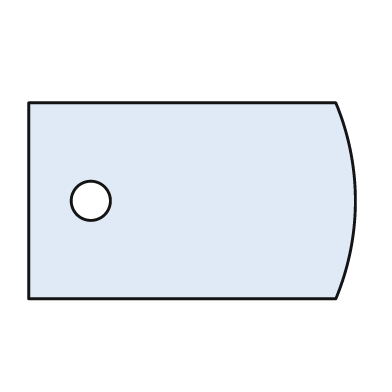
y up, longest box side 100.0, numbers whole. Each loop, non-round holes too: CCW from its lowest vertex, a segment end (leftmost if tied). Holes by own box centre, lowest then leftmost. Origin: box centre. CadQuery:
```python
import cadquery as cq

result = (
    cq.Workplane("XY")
    .moveTo(-50.0, -30.0)
    .lineTo(44.0, -30.0)
    .threePointArc((50.0, 0.0), (44.0, 30.0))
    .lineTo(-50.0, 30.0)
    .close()
    .moveTo(-31.0, 0.0)
    .circle(6.0)
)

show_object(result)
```